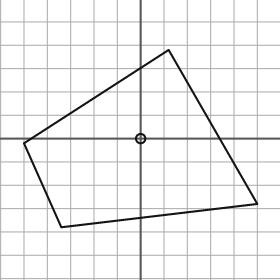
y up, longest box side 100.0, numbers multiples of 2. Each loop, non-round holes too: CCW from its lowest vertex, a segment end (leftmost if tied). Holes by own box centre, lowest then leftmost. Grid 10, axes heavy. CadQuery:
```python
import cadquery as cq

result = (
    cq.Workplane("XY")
    .moveTo(-34.0, -38.0)
    .lineTo(50.0, -28.0)
    .lineTo(12.0, 38.0)
    .lineTo(-50.0, -2.0)
    .close()
    .moveTo(0.0, 0.0)
    .circle(2.0)
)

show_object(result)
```